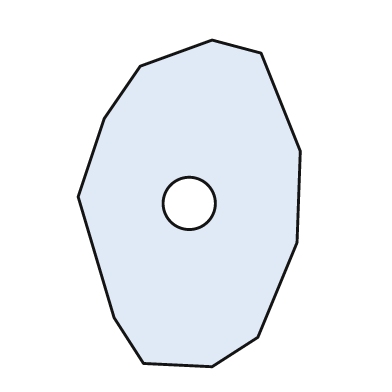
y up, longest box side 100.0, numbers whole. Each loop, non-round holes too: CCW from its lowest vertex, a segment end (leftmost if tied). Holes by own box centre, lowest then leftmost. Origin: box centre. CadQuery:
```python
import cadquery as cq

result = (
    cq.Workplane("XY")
    .moveTo(7.0, -50.0)
    .lineTo(21.0, -41.0)
    .lineTo(33.0, -12.0)
    .lineTo(34.0, 16.0)
    .lineTo(22.0, 46.0)
    .lineTo(7.0, 50.0)
    .lineTo(-15.0, 42.0)
    .lineTo(-26.0, 26.0)
    .lineTo(-34.0, 2.0)
    .lineTo(-23.0, -35.0)
    .lineTo(-14.0, -49.0)
    .close()
    .moveTo(0.0, 0.0)
    .circle(8.0)
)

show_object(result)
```